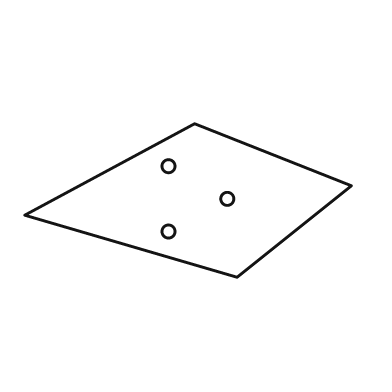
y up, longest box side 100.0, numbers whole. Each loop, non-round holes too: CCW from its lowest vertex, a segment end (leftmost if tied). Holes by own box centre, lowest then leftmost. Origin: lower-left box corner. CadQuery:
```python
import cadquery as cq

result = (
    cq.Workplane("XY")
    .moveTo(65.0, 0.0)
    .lineTo(100.0, 28.0)
    .lineTo(52.0, 47.0)
    .lineTo(0.0, 19.0)
    .close()
    .moveTo(44.0, 14.0)
    .circle(2.0)
    .moveTo(62.0, 24.0)
    .circle(2.0)
    .moveTo(44.0, 34.0)
    .circle(2.0)
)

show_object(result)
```